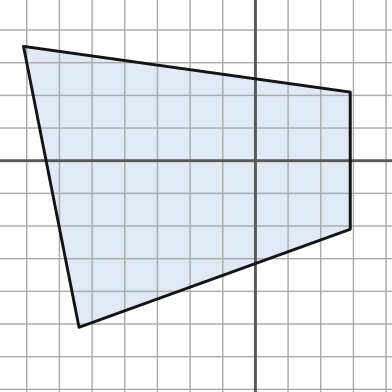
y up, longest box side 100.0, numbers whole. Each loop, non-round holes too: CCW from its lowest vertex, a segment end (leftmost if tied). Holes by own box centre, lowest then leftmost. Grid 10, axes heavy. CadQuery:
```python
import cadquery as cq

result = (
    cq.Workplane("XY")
    .moveTo(-54.0, -51.0)
    .lineTo(29.0, -21.0)
    .lineTo(29.0, 21.0)
    .lineTo(-71.0, 35.0)
    .close()
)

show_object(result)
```